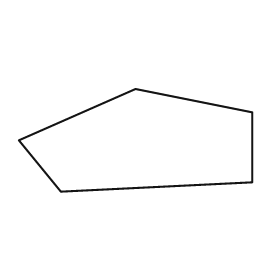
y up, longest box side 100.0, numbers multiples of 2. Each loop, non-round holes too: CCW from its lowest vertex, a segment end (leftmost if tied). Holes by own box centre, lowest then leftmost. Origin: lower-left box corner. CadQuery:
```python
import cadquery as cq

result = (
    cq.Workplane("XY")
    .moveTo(18.0, 0.0)
    .lineTo(100.0, 4.0)
    .lineTo(100.0, 34.0)
    .lineTo(50.0, 44.0)
    .lineTo(0.0, 22.0)
    .close()
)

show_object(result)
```